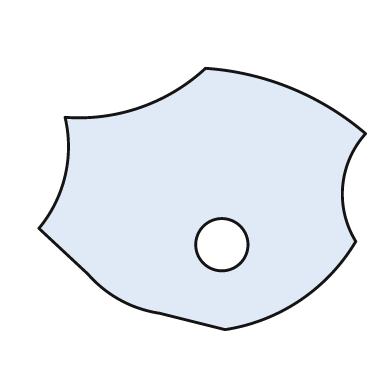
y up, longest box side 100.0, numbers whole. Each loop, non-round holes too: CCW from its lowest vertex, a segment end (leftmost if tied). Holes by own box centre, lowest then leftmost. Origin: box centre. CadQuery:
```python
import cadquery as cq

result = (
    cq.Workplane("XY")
    .moveTo(7.0, -40.0)
    .threePointArc((30.0, -31.0), (47.0, -13.0))
    .threePointArc((43.0, 4.0), (50.0, 20.0))
    .threePointArc((27.0, 34.0), (1.0, 40.0))
    .threePointArc((-19.0, 28.0), (-42.0, 25.0))
    .threePointArc((-42.0, 7.0), (-50.0, -9.0))
    .lineTo(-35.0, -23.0)
    .threePointArc((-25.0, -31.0), (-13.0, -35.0))
    .close()
    .moveTo(6.0, -14.0)
    .circle(8.0)
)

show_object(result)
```